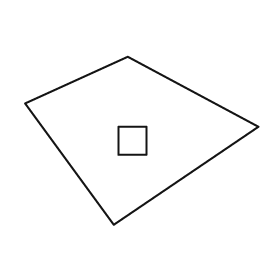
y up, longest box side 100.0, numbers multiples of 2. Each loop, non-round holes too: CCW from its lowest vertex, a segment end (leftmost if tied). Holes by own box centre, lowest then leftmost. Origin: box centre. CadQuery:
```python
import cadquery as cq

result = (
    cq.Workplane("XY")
    .moveTo(-12.0, -36.0)
    .lineTo(50.0, 6.0)
    .lineTo(-6.0, 36.0)
    .lineTo(-50.0, 16.0)
    .close()
    .moveTo(-10.0, -6.0)
    .lineTo(2.0, -6.0)
    .lineTo(2.0, 6.0)
    .lineTo(-10.0, 6.0)
    .close()
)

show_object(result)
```